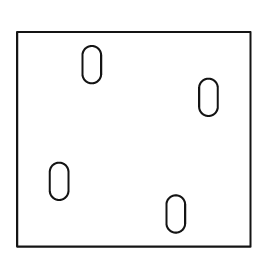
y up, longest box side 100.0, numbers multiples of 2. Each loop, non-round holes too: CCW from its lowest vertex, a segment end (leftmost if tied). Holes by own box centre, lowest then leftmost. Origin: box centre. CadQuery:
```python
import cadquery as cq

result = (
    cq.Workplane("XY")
    .moveTo(-50.0, -46.0)
    .lineTo(50.0, -46.0)
    .lineTo(50.0, 46.0)
    .lineTo(-50.0, 46.0)
    .close()
    .moveTo(14.0, -36.0)
    .threePointArc((18.0, -40.0), (22.0, -36.0))
    .lineTo(22.0, -28.0)
    .threePointArc((18.0, -24.0), (14.0, -28.0))
    .close()
    .moveTo(-36.0, -22.0)
    .threePointArc((-32.0, -26.0), (-28.0, -22.0))
    .lineTo(-28.0, -14.0)
    .threePointArc((-32.0, -10.0), (-36.0, -14.0))
    .close()
    .moveTo(28.0, 14.0)
    .threePointArc((32.0, 10.0), (36.0, 14.0))
    .lineTo(36.0, 22.0)
    .threePointArc((32.0, 26.0), (28.0, 22.0))
    .close()
    .moveTo(-22.0, 28.0)
    .threePointArc((-18.0, 24.0), (-14.0, 28.0))
    .lineTo(-14.0, 36.0)
    .threePointArc((-18.0, 40.0), (-22.0, 36.0))
    .close()
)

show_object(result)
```